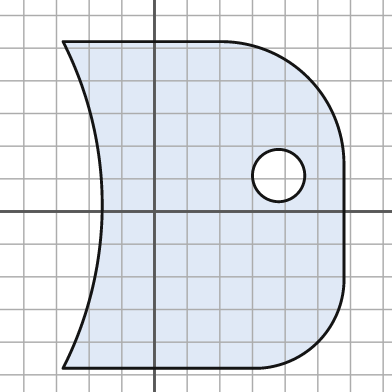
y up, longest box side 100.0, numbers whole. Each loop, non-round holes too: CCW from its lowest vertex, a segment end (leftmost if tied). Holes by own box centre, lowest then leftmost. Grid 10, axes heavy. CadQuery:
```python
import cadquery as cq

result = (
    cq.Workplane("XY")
    .moveTo(-28.0, -48.0)
    .lineTo(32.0, -48.0)
    .threePointArc((50.0, -40.0), (58.0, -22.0))
    .lineTo(58.0, 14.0)
    .threePointArc((47.0, 41.0), (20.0, 52.0))
    .lineTo(-28.0, 52.0)
    .threePointArc((-16.0, 2.0), (-28.0, -48.0))
    .close()
    .moveTo(38.0, 11.0)
    .circle(8.0)
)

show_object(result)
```